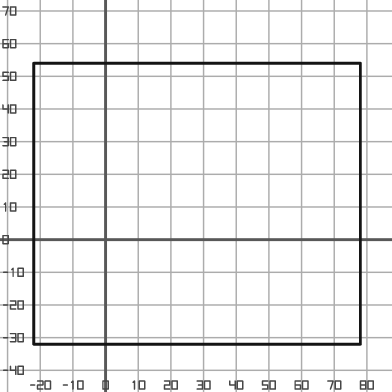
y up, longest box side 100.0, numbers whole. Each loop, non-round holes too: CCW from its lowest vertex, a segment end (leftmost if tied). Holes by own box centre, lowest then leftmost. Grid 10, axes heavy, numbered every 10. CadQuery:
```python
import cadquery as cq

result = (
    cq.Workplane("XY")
    .moveTo(-22.0, -32.0)
    .lineTo(78.0, -32.0)
    .lineTo(78.0, 54.0)
    .lineTo(-22.0, 54.0)
    .close()
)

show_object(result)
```